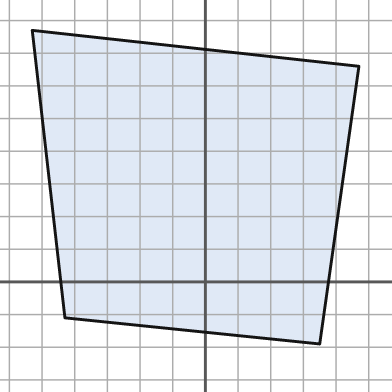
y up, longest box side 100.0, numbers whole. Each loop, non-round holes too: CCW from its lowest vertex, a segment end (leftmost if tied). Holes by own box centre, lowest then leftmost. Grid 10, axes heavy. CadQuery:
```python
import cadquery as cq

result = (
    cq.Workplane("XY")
    .moveTo(35.0, -19.0)
    .lineTo(47.0, 66.0)
    .lineTo(-53.0, 77.0)
    .lineTo(-43.0, -11.0)
    .close()
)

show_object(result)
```